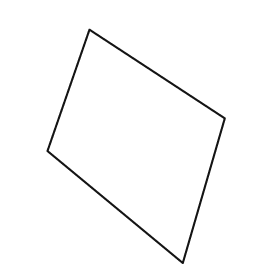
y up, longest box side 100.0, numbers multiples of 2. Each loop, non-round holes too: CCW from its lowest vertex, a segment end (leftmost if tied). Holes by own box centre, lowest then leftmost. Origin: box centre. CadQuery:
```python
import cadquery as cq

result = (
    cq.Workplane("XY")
    .moveTo(20.0, -50.0)
    .lineTo(38.0, 12.0)
    .lineTo(-20.0, 50.0)
    .lineTo(-38.0, -2.0)
    .close()
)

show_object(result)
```